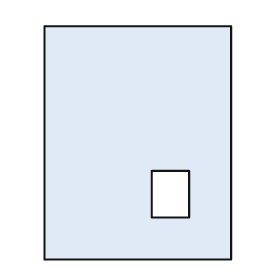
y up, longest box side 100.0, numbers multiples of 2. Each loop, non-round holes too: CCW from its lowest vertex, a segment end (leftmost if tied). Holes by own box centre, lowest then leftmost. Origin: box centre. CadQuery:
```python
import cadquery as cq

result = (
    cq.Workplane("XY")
    .moveTo(-40.0, -50.0)
    .lineTo(40.0, -50.0)
    .lineTo(40.0, 50.0)
    .lineTo(-40.0, 50.0)
    .close()
    .moveTo(6.0, -32.0)
    .lineTo(22.0, -32.0)
    .lineTo(22.0, -12.0)
    .lineTo(6.0, -12.0)
    .close()
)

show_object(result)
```